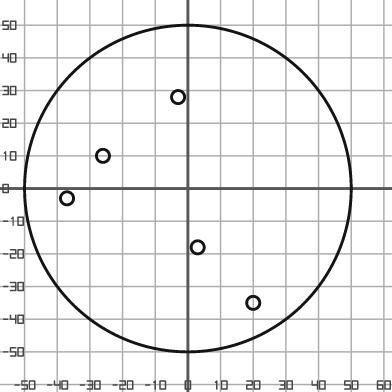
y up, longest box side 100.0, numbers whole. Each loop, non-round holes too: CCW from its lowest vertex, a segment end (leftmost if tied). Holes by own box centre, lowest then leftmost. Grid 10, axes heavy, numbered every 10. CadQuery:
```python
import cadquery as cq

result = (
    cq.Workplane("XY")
    .moveTo(0.0, 0.0)
    .circle(50.0)
    .moveTo(20.0, -35.0)
    .circle(2.0)
    .moveTo(3.0, -18.0)
    .circle(2.0)
    .moveTo(-37.0, -3.0)
    .circle(2.0)
    .moveTo(-26.0, 10.0)
    .circle(2.0)
    .moveTo(-3.0, 28.0)
    .circle(2.0)
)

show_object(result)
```